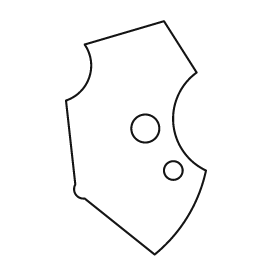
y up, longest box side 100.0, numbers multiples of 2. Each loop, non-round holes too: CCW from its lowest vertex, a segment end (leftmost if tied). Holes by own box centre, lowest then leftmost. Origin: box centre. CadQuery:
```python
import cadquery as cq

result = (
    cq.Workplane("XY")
    .moveTo(8.0, -50.0)
    .threePointArc((22.0, -34.0), (30.0, -14.0))
    .threePointArc((16.0, 6.0), (26.0, 28.0))
    .lineTo(12.0, 50.0)
    .lineTo(-22.0, 40.0)
    .threePointArc((-20.0, 26.0), (-30.0, 16.0))
    .lineTo(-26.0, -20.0)
    .threePointArc((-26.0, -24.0), (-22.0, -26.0))
    .close()
    .moveTo(16.0, -14.0)
    .circle(4.0)
    .moveTo(4.0, 4.0)
    .circle(6.0)
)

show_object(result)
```